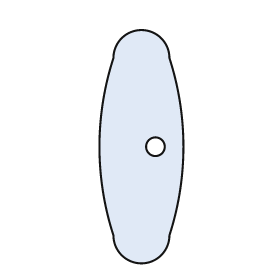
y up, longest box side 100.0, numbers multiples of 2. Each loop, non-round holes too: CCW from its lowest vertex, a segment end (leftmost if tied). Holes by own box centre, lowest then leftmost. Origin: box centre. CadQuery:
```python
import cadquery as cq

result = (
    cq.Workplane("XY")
    .moveTo(-12.0, -38.0)
    .threePointArc((0.0, -50.0), (12.0, -38.0))
    .threePointArc((18.0, 0.0), (12.0, 38.0))
    .threePointArc((0.0, 50.0), (-12.0, 38.0))
    .threePointArc((-18.0, 0.0), (-12.0, -38.0))
    .close()
    .moveTo(6.0, 0.0)
    .circle(4.0)
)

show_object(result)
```